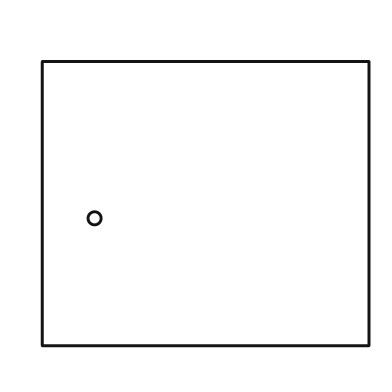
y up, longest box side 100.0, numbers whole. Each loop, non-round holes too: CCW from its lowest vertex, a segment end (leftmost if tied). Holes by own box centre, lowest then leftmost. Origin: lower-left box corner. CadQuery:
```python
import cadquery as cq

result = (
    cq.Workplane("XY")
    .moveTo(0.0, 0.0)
    .lineTo(100.0, 0.0)
    .lineTo(100.0, 87.0)
    .lineTo(0.0, 87.0)
    .close()
    .moveTo(16.0, 39.0)
    .circle(2.0)
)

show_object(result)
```